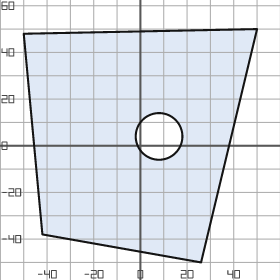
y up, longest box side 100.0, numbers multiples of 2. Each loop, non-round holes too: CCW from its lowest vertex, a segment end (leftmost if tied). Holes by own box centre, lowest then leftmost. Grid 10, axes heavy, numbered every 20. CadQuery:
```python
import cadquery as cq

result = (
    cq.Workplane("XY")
    .moveTo(26.0, -50.0)
    .lineTo(50.0, 50.0)
    .lineTo(-50.0, 48.0)
    .lineTo(-42.0, -38.0)
    .close()
    .moveTo(8.0, 4.0)
    .circle(10.0)
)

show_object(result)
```